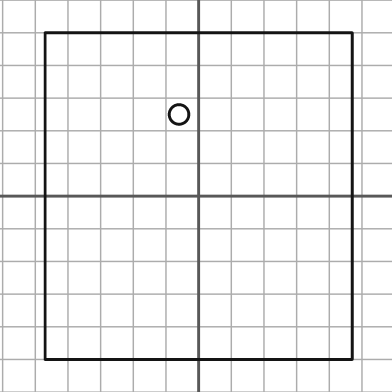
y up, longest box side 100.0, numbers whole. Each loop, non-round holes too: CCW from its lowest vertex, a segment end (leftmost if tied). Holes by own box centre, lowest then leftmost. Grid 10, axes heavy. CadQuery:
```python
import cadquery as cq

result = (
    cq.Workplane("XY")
    .moveTo(-47.0, -50.0)
    .lineTo(47.0, -50.0)
    .lineTo(47.0, 50.0)
    .lineTo(-47.0, 50.0)
    .close()
    .moveTo(-6.0, 25.0)
    .circle(3.0)
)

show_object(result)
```